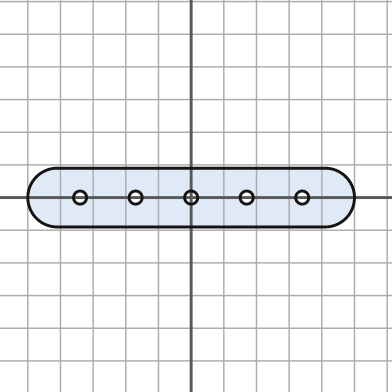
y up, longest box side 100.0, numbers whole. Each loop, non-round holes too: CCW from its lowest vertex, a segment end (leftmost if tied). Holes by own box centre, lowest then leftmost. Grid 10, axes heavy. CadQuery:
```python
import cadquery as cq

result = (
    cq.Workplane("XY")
    .moveTo(-41.0, -9.0)
    .lineTo(41.0, -9.0)
    .threePointArc((50.0, 0.0), (41.0, 9.0))
    .lineTo(-41.0, 9.0)
    .threePointArc((-50.0, 0.0), (-41.0, -9.0))
    .close()
    .moveTo(-34.0, 0.0)
    .circle(2.0)
    .moveTo(-17.0, 0.0)
    .circle(2.0)
    .moveTo(0.0, 0.0)
    .circle(2.0)
    .moveTo(17.0, 0.0)
    .circle(2.0)
    .moveTo(34.0, 0.0)
    .circle(2.0)
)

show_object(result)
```